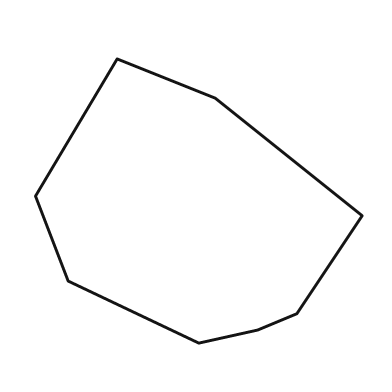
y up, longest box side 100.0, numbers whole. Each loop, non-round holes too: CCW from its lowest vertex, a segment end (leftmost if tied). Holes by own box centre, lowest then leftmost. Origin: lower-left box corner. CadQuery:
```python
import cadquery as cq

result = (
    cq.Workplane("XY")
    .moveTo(50.0, 0.0)
    .lineTo(68.0, 4.0)
    .lineTo(80.0, 9.0)
    .lineTo(100.0, 39.0)
    .lineTo(55.0, 75.0)
    .lineTo(25.0, 87.0)
    .lineTo(0.0, 45.0)
    .lineTo(10.0, 19.0)
    .close()
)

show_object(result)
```